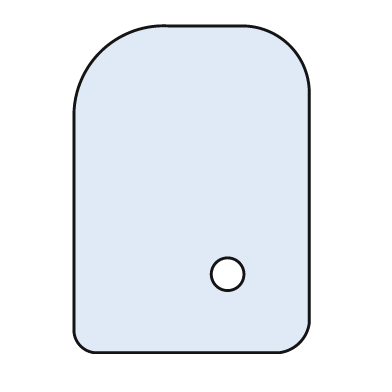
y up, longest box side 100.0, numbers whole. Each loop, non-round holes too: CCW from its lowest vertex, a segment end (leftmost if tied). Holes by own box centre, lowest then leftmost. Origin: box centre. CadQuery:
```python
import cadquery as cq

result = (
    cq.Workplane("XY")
    .moveTo(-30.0, -50.0)
    .lineTo(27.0, -50.0)
    .threePointArc((33.0, -47.0), (36.0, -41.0))
    .lineTo(36.0, 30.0)
    .threePointArc((30.0, 44.0), (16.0, 50.0))
    .lineTo(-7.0, 50.0)
    .threePointArc((-28.0, 42.0), (-36.0, 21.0))
    .lineTo(-36.0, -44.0)
    .threePointArc((-34.0, -48.0), (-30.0, -50.0))
    .close()
    .moveTo(11.0, -26.0)
    .circle(5.0)
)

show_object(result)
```